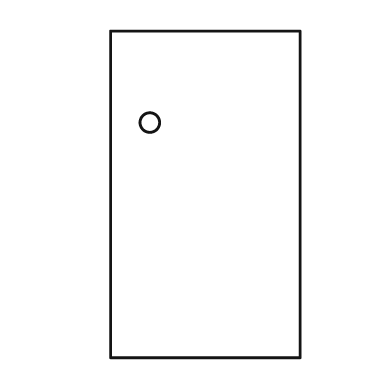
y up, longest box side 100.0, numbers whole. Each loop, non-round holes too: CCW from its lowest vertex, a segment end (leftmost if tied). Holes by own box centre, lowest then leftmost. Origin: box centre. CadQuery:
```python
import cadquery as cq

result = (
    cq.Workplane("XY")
    .moveTo(-29.0, -50.0)
    .lineTo(29.0, -50.0)
    .lineTo(29.0, 50.0)
    .lineTo(-29.0, 50.0)
    .close()
    .moveTo(-17.0, 22.0)
    .circle(3.0)
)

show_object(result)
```